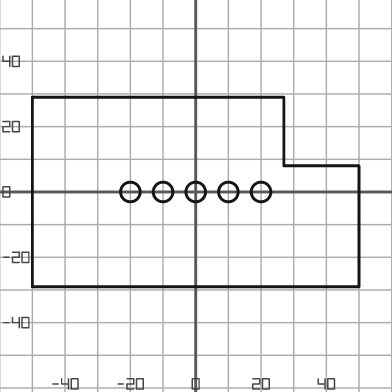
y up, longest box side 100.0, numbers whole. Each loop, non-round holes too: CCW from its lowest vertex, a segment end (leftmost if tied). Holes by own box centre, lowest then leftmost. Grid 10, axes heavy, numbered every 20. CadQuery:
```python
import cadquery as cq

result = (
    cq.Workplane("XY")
    .moveTo(-50.0, -29.0)
    .lineTo(50.0, -29.0)
    .lineTo(50.0, 8.0)
    .lineTo(27.0, 8.0)
    .lineTo(27.0, 29.0)
    .lineTo(-50.0, 29.0)
    .close()
    .moveTo(-20.0, 0.0)
    .circle(3.0)
    .moveTo(-10.0, 0.0)
    .circle(3.0)
    .moveTo(0.0, 0.0)
    .circle(3.0)
    .moveTo(10.0, 0.0)
    .circle(3.0)
    .moveTo(20.0, 0.0)
    .circle(3.0)
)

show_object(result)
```